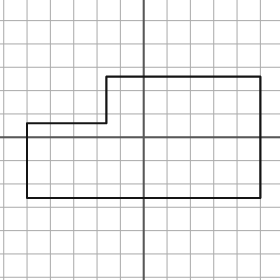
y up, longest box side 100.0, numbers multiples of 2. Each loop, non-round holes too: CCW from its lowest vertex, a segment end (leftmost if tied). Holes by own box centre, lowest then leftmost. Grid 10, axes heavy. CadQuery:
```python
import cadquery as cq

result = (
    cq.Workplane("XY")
    .moveTo(-50.0, -26.0)
    .lineTo(50.0, -26.0)
    .lineTo(50.0, 26.0)
    .lineTo(-16.0, 26.0)
    .lineTo(-16.0, 6.0)
    .lineTo(-50.0, 6.0)
    .close()
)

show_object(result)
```